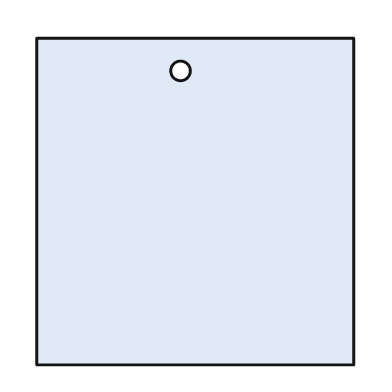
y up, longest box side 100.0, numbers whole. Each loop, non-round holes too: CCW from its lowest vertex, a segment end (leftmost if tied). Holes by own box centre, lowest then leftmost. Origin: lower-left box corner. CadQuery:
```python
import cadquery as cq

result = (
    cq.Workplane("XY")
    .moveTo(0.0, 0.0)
    .lineTo(97.0, 0.0)
    .lineTo(97.0, 100.0)
    .lineTo(0.0, 100.0)
    .close()
    .moveTo(44.0, 90.0)
    .circle(3.0)
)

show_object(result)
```